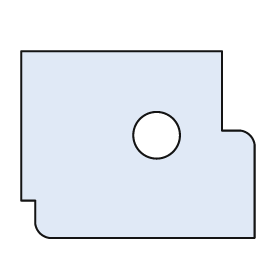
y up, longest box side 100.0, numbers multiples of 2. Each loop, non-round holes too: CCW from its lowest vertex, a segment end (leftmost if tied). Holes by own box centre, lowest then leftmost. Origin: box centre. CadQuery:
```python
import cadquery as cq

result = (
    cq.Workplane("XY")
    .moveTo(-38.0, -40.0)
    .lineTo(50.0, -40.0)
    .lineTo(50.0, 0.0)
    .threePointArc((48.0, 4.0), (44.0, 6.0))
    .lineTo(36.0, 6.0)
    .lineTo(36.0, 40.0)
    .lineTo(-50.0, 40.0)
    .lineTo(-50.0, -24.0)
    .lineTo(-44.0, -24.0)
    .lineTo(-44.0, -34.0)
    .threePointArc((-42.0, -38.0), (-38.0, -40.0))
    .close()
    .moveTo(8.0, 4.0)
    .circle(10.0)
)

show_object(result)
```